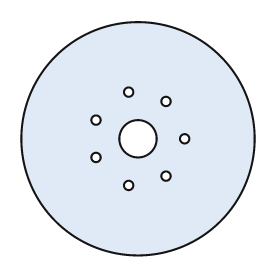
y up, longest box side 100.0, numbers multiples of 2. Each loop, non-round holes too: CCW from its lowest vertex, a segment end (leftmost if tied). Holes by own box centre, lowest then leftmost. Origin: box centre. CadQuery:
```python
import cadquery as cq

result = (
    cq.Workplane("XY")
    .moveTo(0.0, 0.0)
    .circle(50.0)
    .moveTo(-4.0, -20.0)
    .circle(2.0)
    .moveTo(12.0, -16.0)
    .circle(2.0)
    .moveTo(-18.0, -8.0)
    .circle(2.0)
    .moveTo(0.0, 0.0)
    .circle(8.0)
    .moveTo(20.0, 0.0)
    .circle(2.0)
    .moveTo(-18.0, 8.0)
    .circle(2.0)
    .moveTo(12.0, 16.0)
    .circle(2.0)
    .moveTo(-4.0, 20.0)
    .circle(2.0)
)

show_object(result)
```